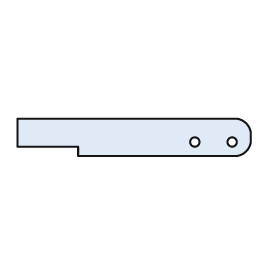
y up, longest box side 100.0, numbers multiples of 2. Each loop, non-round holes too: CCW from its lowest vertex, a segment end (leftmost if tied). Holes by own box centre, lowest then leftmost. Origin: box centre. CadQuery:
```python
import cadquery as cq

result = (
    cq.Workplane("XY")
    .moveTo(-24.0, -8.0)
    .lineTo(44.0, -8.0)
    .threePointArc((48.0, -6.0), (50.0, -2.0))
    .lineTo(50.0, 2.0)
    .threePointArc((48.0, 6.0), (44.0, 8.0))
    .lineTo(-50.0, 8.0)
    .lineTo(-50.0, -4.0)
    .lineTo(-24.0, -4.0)
    .close()
    .moveTo(26.0, -2.0)
    .circle(2.0)
    .moveTo(42.0, -2.0)
    .circle(2.0)
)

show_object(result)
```